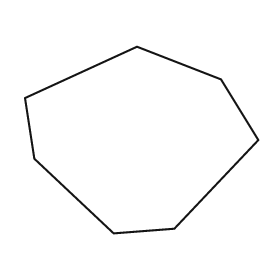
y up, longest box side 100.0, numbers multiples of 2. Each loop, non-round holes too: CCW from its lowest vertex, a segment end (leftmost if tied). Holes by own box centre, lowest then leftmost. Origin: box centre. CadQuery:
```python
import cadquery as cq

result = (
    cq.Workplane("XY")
    .moveTo(-12.0, -40.0)
    .lineTo(14.0, -38.0)
    .lineTo(50.0, 0.0)
    .lineTo(34.0, 26.0)
    .lineTo(-2.0, 40.0)
    .lineTo(-50.0, 18.0)
    .lineTo(-46.0, -8.0)
    .close()
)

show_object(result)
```